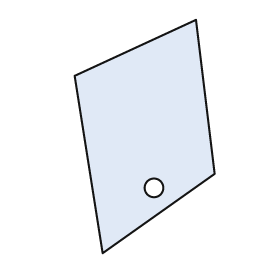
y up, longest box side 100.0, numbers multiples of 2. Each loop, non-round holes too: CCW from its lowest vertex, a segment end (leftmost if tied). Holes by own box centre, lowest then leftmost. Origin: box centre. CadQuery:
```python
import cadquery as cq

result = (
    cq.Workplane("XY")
    .moveTo(-18.0, -50.0)
    .lineTo(30.0, -16.0)
    .lineTo(22.0, 50.0)
    .lineTo(-30.0, 26.0)
    .close()
    .moveTo(4.0, -22.0)
    .circle(4.0)
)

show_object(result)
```